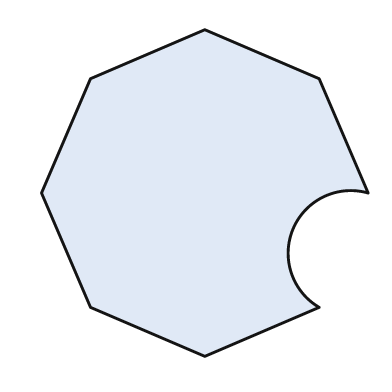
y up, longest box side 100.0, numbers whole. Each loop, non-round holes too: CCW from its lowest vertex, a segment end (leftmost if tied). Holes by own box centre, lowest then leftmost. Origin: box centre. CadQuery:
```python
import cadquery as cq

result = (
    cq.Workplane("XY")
    .moveTo(0.0, -50.0)
    .lineTo(35.0, -35.0)
    .threePointArc((27.0, -11.0), (50.0, 0.0))
    .lineTo(35.0, 35.0)
    .lineTo(0.0, 50.0)
    .lineTo(-35.0, 35.0)
    .lineTo(-50.0, 0.0)
    .lineTo(-35.0, -35.0)
    .close()
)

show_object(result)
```